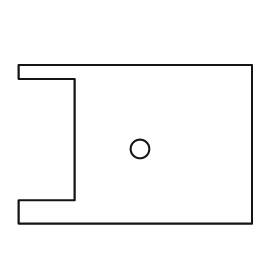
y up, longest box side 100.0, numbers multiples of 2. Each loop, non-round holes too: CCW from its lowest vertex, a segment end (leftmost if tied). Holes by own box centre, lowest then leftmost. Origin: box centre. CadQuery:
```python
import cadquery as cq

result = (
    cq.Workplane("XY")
    .moveTo(-50.0, -34.0)
    .lineTo(50.0, -34.0)
    .lineTo(50.0, 34.0)
    .lineTo(-50.0, 34.0)
    .lineTo(-50.0, 28.0)
    .lineTo(-26.0, 28.0)
    .lineTo(-26.0, -24.0)
    .lineTo(-50.0, -24.0)
    .close()
    .moveTo(2.0, -2.0)
    .circle(4.0)
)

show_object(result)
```